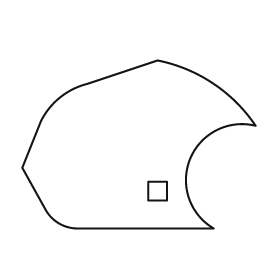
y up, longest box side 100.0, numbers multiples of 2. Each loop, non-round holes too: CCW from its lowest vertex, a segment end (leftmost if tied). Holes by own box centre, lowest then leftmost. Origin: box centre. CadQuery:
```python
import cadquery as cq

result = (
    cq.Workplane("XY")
    .moveTo(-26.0, -36.0)
    .lineTo(32.0, -36.0)
    .threePointArc((22.0, -6.0), (50.0, 8.0))
    .threePointArc((32.0, 26.0), (8.0, 36.0))
    .lineTo(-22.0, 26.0)
    .threePointArc((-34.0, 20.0), (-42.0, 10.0))
    .lineTo(-50.0, -10.0)
    .lineTo(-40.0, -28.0)
    .threePointArc((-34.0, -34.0), (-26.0, -36.0))
    .close()
    .moveTo(4.0, -24.0)
    .lineTo(12.0, -24.0)
    .lineTo(12.0, -16.0)
    .lineTo(4.0, -16.0)
    .close()
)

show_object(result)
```